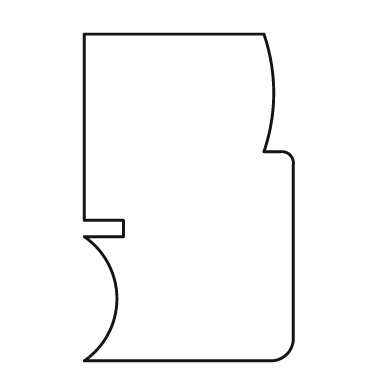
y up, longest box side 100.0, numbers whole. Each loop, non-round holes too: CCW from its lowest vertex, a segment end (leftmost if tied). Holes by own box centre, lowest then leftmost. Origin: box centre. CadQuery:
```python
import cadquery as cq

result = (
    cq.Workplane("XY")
    .moveTo(-32.0, -50.0)
    .lineTo(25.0, -50.0)
    .threePointArc((30.0, -48.0), (32.0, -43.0))
    .lineTo(32.0, 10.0)
    .threePointArc((31.0, 13.0), (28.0, 14.0))
    .lineTo(23.0, 14.0)
    .threePointArc((26.0, 32.0), (23.0, 50.0))
    .lineTo(-32.0, 50.0)
    .lineTo(-32.0, -7.0)
    .lineTo(-20.0, -7.0)
    .lineTo(-20.0, -12.0)
    .lineTo(-32.0, -12.0)
    .threePointArc((-22.0, -31.0), (-32.0, -50.0))
    .close()
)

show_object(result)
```